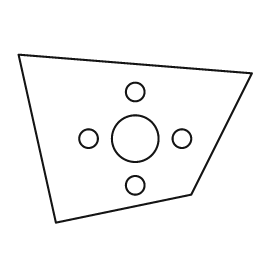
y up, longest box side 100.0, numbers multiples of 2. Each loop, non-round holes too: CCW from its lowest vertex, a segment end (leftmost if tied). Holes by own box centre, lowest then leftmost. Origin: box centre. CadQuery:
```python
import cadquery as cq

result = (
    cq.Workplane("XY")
    .moveTo(-34.0, -36.0)
    .lineTo(24.0, -24.0)
    .lineTo(50.0, 28.0)
    .lineTo(-50.0, 36.0)
    .close()
    .moveTo(0.0, -20.0)
    .circle(4.0)
    .moveTo(-20.0, 0.0)
    .circle(4.0)
    .moveTo(0.0, 0.0)
    .circle(10.0)
    .moveTo(20.0, 0.0)
    .circle(4.0)
    .moveTo(0.0, 20.0)
    .circle(4.0)
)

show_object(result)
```